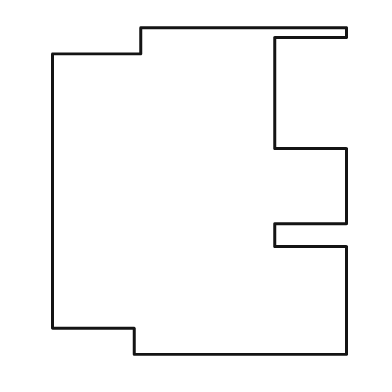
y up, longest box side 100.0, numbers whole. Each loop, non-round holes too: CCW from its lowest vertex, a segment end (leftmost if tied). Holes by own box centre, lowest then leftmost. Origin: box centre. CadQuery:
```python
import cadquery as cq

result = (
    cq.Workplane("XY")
    .moveTo(-20.0, -50.0)
    .lineTo(45.0, -50.0)
    .lineTo(45.0, -17.0)
    .lineTo(23.0, -17.0)
    .lineTo(23.0, -10.0)
    .lineTo(45.0, -10.0)
    .lineTo(45.0, 13.0)
    .lineTo(23.0, 13.0)
    .lineTo(23.0, 47.0)
    .lineTo(45.0, 47.0)
    .lineTo(45.0, 50.0)
    .lineTo(-18.0, 50.0)
    .lineTo(-18.0, 42.0)
    .lineTo(-45.0, 42.0)
    .lineTo(-45.0, -42.0)
    .lineTo(-20.0, -42.0)
    .close()
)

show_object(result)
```